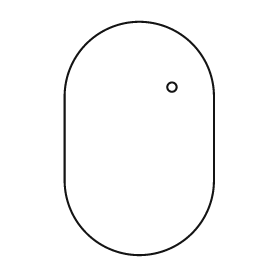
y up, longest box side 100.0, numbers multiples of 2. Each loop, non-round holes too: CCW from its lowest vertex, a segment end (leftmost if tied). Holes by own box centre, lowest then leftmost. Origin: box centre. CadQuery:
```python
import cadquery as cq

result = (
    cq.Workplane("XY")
    .moveTo(-32.0, -18.0)
    .threePointArc((0.0, -50.0), (32.0, -18.0))
    .lineTo(32.0, 18.0)
    .threePointArc((0.0, 50.0), (-32.0, 18.0))
    .close()
    .moveTo(14.0, 22.0)
    .circle(2.0)
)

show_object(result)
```